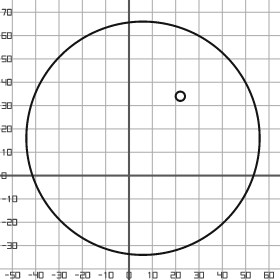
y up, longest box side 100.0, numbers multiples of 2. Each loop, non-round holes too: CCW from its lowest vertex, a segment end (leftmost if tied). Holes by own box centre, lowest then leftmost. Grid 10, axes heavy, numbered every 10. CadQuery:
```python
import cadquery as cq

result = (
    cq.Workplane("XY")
    .moveTo(6.0, 16.0)
    .circle(50.0)
    .moveTo(22.0, 34.0)
    .circle(2.0)
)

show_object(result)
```